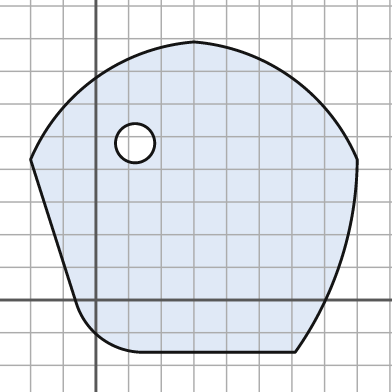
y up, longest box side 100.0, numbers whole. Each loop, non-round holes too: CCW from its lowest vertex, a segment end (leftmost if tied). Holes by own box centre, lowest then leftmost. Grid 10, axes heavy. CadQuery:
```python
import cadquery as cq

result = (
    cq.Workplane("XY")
    .moveTo(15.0, -16.0)
    .lineTo(61.0, -16.0)
    .threePointArc((75.0, 12.0), (80.0, 43.0))
    .threePointArc((60.0, 68.0), (30.0, 79.0))
    .threePointArc((0.0, 68.0), (-20.0, 43.0))
    .lineTo(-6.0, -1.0)
    .threePointArc((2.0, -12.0), (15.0, -16.0))
    .close()
    .moveTo(12.0, 48.0)
    .circle(6.0)
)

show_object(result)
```